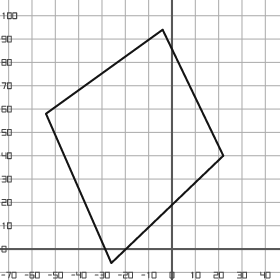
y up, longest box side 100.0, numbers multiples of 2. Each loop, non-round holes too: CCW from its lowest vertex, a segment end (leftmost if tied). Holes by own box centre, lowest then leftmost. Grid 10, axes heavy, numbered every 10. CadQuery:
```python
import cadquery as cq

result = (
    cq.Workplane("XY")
    .moveTo(-26.0, -6.0)
    .lineTo(22.0, 40.0)
    .lineTo(-4.0, 94.0)
    .lineTo(-54.0, 58.0)
    .close()
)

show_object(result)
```